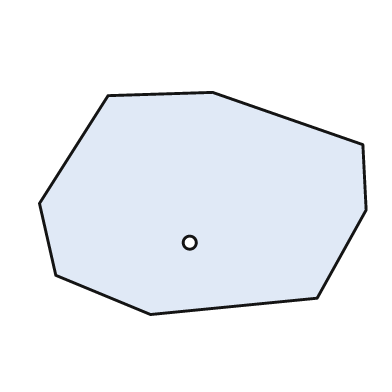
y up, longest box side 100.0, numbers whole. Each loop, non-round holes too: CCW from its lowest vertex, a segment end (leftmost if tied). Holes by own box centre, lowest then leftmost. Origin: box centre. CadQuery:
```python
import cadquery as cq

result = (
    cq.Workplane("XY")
    .moveTo(-16.0, -34.0)
    .lineTo(35.0, -29.0)
    .lineTo(50.0, -2.0)
    .lineTo(49.0, 18.0)
    .lineTo(3.0, 34.0)
    .lineTo(-29.0, 33.0)
    .lineTo(-50.0, 0.0)
    .lineTo(-45.0, -22.0)
    .close()
    .moveTo(-4.0, -12.0)
    .circle(2.0)
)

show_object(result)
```